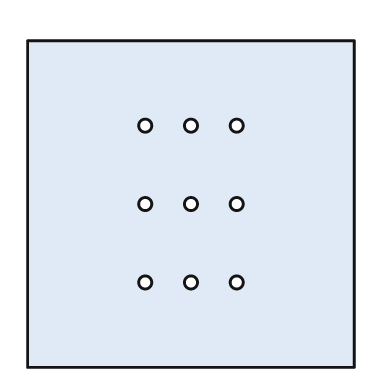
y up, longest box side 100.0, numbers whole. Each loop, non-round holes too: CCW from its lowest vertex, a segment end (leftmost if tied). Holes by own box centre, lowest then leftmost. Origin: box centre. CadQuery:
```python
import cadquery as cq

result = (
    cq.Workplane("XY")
    .moveTo(-50.0, -50.0)
    .lineTo(50.0, -50.0)
    .lineTo(50.0, 50.0)
    .lineTo(-50.0, 50.0)
    .close()
    .moveTo(-14.0, -24.0)
    .circle(2.0)
    .moveTo(0.0, -24.0)
    .circle(2.0)
    .moveTo(14.0, -24.0)
    .circle(2.0)
    .moveTo(-14.0, 0.0)
    .circle(2.0)
    .moveTo(0.0, 0.0)
    .circle(2.0)
    .moveTo(14.0, 0.0)
    .circle(2.0)
    .moveTo(-14.0, 24.0)
    .circle(2.0)
    .moveTo(0.0, 24.0)
    .circle(2.0)
    .moveTo(14.0, 24.0)
    .circle(2.0)
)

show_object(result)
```